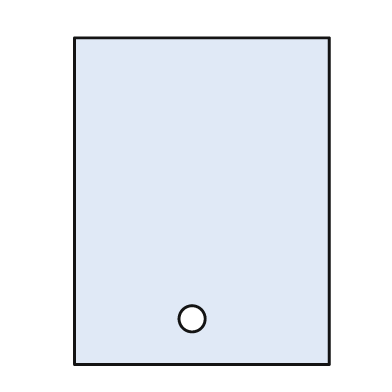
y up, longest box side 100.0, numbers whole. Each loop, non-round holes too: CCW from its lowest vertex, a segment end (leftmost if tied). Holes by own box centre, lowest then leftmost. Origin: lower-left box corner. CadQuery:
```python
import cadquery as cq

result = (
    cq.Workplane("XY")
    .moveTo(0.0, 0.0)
    .lineTo(78.0, 0.0)
    .lineTo(78.0, 100.0)
    .lineTo(0.0, 100.0)
    .close()
    .moveTo(36.0, 14.0)
    .circle(4.0)
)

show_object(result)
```